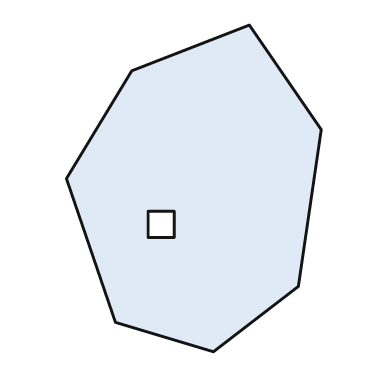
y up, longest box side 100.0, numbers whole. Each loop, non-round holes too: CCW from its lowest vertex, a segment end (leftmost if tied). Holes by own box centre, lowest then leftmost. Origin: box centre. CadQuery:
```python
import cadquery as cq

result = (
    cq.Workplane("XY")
    .moveTo(6.0, -50.0)
    .lineTo(32.0, -30.0)
    .lineTo(39.0, 18.0)
    .lineTo(17.0, 50.0)
    .lineTo(-19.0, 36.0)
    .lineTo(-39.0, 3.0)
    .lineTo(-24.0, -41.0)
    .close()
    .moveTo(-14.0, -15.0)
    .lineTo(-6.0, -15.0)
    .lineTo(-6.0, -7.0)
    .lineTo(-14.0, -7.0)
    .close()
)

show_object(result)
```